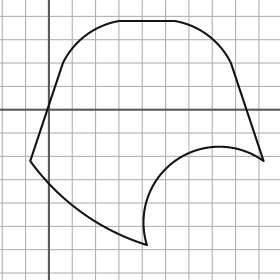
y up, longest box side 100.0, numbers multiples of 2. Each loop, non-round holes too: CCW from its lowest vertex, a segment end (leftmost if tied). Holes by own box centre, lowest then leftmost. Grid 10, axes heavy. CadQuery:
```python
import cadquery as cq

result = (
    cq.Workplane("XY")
    .moveTo(42.0, -58.0)
    .threePointArc((54.0, -22.0), (92.0, -22.0))
    .lineTo(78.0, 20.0)
    .threePointArc((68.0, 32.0), (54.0, 38.0))
    .lineTo(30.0, 38.0)
    .threePointArc((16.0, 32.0), (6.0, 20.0))
    .lineTo(-8.0, -22.0)
    .threePointArc((14.0, -44.0), (42.0, -58.0))
    .close()
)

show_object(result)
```